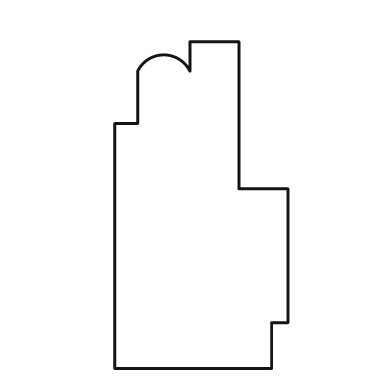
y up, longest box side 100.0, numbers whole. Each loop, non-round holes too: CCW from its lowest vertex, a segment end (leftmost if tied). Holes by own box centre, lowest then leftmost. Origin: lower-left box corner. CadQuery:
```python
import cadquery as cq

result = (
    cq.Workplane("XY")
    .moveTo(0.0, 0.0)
    .lineTo(48.0, 0.0)
    .lineTo(48.0, 14.0)
    .lineTo(53.0, 14.0)
    .lineTo(53.0, 55.0)
    .lineTo(38.0, 55.0)
    .lineTo(38.0, 100.0)
    .lineTo(23.0, 100.0)
    .lineTo(23.0, 91.0)
    .threePointArc((15.0, 96.0), (7.0, 91.0))
    .lineTo(7.0, 75.0)
    .lineTo(0.0, 75.0)
    .close()
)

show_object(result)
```